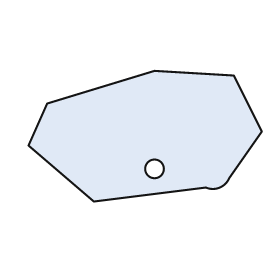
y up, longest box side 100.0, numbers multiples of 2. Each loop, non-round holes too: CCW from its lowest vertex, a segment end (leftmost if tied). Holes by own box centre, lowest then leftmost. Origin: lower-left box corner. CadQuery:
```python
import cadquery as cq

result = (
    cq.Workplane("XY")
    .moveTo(28.0, 0.0)
    .lineTo(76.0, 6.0)
    .threePointArc((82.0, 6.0), (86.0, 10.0))
    .lineTo(100.0, 30.0)
    .lineTo(88.0, 54.0)
    .lineTo(54.0, 56.0)
    .lineTo(8.0, 42.0)
    .lineTo(0.0, 24.0)
    .close()
    .moveTo(54.0, 14.0)
    .circle(4.0)
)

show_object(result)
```